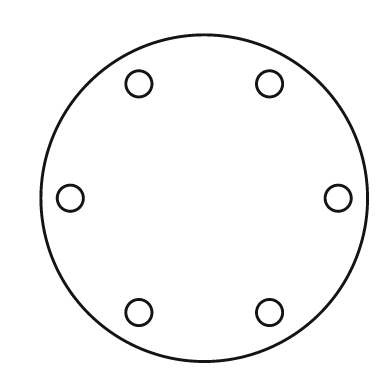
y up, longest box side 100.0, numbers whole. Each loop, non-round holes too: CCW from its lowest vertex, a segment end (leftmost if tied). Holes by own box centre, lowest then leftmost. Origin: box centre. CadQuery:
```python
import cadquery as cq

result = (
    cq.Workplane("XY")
    .moveTo(0.0, 0.0)
    .circle(50.0)
    .moveTo(-20.0, -35.0)
    .circle(4.0)
    .moveTo(20.0, -35.0)
    .circle(4.0)
    .moveTo(-41.0, 0.0)
    .circle(4.0)
    .moveTo(41.0, 0.0)
    .circle(4.0)
    .moveTo(-20.0, 35.0)
    .circle(4.0)
    .moveTo(20.0, 35.0)
    .circle(4.0)
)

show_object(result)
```